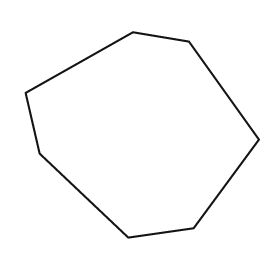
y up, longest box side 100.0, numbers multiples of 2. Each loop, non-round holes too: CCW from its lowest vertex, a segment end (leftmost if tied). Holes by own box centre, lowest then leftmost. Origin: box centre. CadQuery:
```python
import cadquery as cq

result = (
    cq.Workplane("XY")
    .moveTo(-6.0, -44.0)
    .lineTo(22.0, -40.0)
    .lineTo(50.0, -2.0)
    .lineTo(20.0, 40.0)
    .lineTo(-4.0, 44.0)
    .lineTo(-50.0, 18.0)
    .lineTo(-44.0, -8.0)
    .close()
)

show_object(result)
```